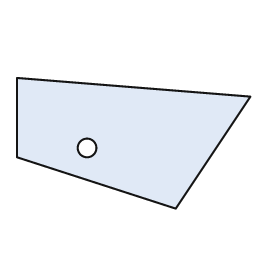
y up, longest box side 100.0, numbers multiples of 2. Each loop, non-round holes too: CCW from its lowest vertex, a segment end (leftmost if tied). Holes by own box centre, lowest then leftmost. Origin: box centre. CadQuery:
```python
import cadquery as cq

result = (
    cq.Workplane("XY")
    .moveTo(18.0, -28.0)
    .lineTo(50.0, 20.0)
    .lineTo(-50.0, 28.0)
    .lineTo(-50.0, -6.0)
    .close()
    .moveTo(-20.0, -2.0)
    .circle(4.0)
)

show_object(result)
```